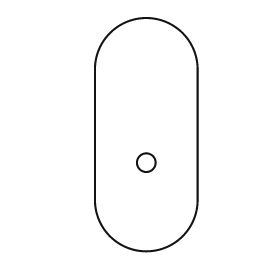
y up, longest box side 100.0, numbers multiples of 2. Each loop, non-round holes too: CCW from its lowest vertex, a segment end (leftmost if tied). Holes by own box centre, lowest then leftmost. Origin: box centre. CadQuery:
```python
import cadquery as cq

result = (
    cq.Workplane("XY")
    .moveTo(-22.0, -28.0)
    .threePointArc((0.0, -50.0), (22.0, -28.0))
    .lineTo(22.0, 28.0)
    .threePointArc((0.0, 50.0), (-22.0, 28.0))
    .close()
    .moveTo(0.0, -12.0)
    .circle(4.0)
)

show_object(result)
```